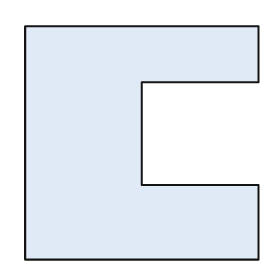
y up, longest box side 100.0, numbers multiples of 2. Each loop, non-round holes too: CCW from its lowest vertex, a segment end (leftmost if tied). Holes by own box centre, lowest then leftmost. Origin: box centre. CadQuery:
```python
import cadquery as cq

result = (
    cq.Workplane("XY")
    .moveTo(-50.0, -50.0)
    .lineTo(50.0, -50.0)
    .lineTo(50.0, -18.0)
    .lineTo(0.0, -18.0)
    .lineTo(0.0, 26.0)
    .lineTo(50.0, 26.0)
    .lineTo(50.0, 50.0)
    .lineTo(-50.0, 50.0)
    .close()
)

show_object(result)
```